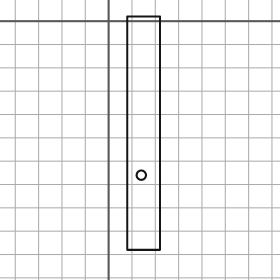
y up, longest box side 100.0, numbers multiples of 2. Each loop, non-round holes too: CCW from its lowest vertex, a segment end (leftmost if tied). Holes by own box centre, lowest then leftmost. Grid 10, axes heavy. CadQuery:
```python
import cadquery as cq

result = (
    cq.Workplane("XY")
    .moveTo(8.0, -98.0)
    .lineTo(22.0, -98.0)
    .lineTo(22.0, 2.0)
    .lineTo(8.0, 2.0)
    .close()
    .moveTo(14.0, -66.0)
    .circle(2.0)
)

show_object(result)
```